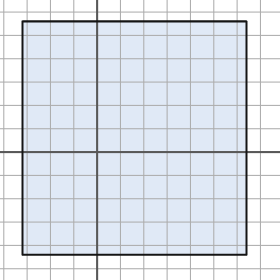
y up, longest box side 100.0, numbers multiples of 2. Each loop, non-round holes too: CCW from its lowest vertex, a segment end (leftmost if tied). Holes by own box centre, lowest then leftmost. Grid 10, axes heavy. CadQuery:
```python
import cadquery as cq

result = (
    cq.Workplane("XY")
    .moveTo(-32.0, -44.0)
    .lineTo(64.0, -44.0)
    .lineTo(64.0, 56.0)
    .lineTo(-32.0, 56.0)
    .close()
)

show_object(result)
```